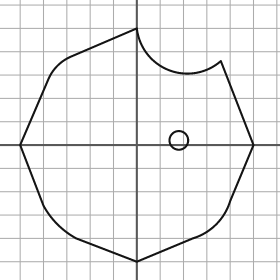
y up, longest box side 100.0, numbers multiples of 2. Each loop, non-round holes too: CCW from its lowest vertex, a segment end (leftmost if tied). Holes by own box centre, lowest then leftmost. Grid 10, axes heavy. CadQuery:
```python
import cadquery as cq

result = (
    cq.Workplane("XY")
    .moveTo(0.0, -50.0)
    .lineTo(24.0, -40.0)
    .threePointArc((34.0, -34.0), (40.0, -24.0))
    .lineTo(50.0, 0.0)
    .lineTo(36.0, 36.0)
    .threePointArc((14.0, 32.0), (0.0, 50.0))
    .lineTo(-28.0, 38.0)
    .threePointArc((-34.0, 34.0), (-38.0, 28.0))
    .lineTo(-50.0, 0.0)
    .lineTo(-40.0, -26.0)
    .threePointArc((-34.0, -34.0), (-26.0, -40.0))
    .close()
    .moveTo(18.0, 2.0)
    .circle(4.0)
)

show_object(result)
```